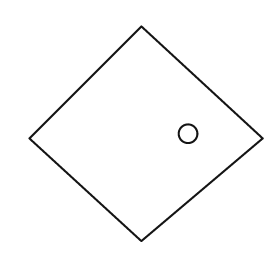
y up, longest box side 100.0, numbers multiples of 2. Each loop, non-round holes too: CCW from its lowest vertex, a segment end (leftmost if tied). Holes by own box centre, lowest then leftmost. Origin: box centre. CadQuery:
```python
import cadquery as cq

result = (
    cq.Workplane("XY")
    .moveTo(-2.0, -46.0)
    .lineTo(50.0, -2.0)
    .lineTo(-2.0, 46.0)
    .lineTo(-50.0, -2.0)
    .close()
    .moveTo(18.0, 0.0)
    .circle(4.0)
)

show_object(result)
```